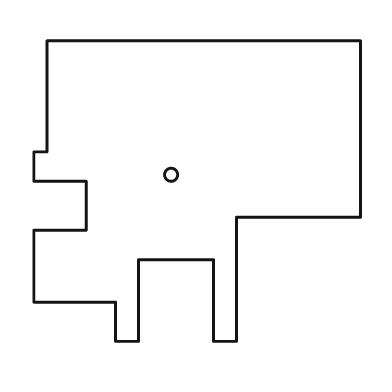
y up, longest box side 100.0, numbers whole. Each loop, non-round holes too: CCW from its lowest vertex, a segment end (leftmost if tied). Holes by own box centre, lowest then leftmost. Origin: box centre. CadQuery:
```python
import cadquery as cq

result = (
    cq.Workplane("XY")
    .moveTo(-25.0, -46.0)
    .lineTo(-18.0, -46.0)
    .lineTo(-18.0, -21.0)
    .lineTo(5.0, -21.0)
    .lineTo(5.0, -46.0)
    .lineTo(12.0, -46.0)
    .lineTo(12.0, -8.0)
    .lineTo(50.0, -8.0)
    .lineTo(50.0, 46.0)
    .lineTo(-46.0, 46.0)
    .lineTo(-46.0, 12.0)
    .lineTo(-50.0, 12.0)
    .lineTo(-50.0, 3.0)
    .lineTo(-34.0, 3.0)
    .lineTo(-34.0, -12.0)
    .lineTo(-50.0, -12.0)
    .lineTo(-50.0, -34.0)
    .lineTo(-25.0, -34.0)
    .close()
    .moveTo(-8.0, 5.0)
    .circle(2.0)
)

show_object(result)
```